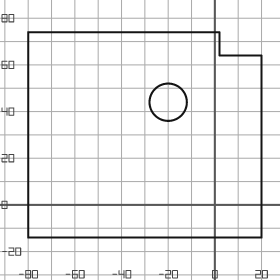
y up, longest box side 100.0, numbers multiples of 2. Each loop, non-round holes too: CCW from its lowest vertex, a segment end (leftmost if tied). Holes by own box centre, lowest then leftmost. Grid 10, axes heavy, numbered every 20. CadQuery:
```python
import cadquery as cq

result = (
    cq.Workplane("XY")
    .moveTo(-80.0, -14.0)
    .lineTo(20.0, -14.0)
    .lineTo(20.0, 64.0)
    .lineTo(2.0, 64.0)
    .lineTo(2.0, 74.0)
    .lineTo(-80.0, 74.0)
    .close()
    .moveTo(-20.0, 44.0)
    .circle(8.0)
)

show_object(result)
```